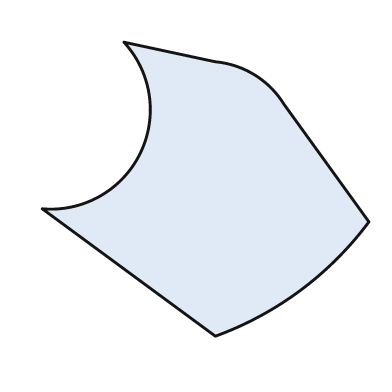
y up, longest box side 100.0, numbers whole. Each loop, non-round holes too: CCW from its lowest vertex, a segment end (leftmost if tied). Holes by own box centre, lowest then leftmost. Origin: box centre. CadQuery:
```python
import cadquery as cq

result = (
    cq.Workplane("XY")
    .moveTo(3.0, -45.0)
    .threePointArc((29.0, -31.0), (50.0, -10.0))
    .lineTo(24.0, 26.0)
    .threePointArc((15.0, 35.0), (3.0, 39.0))
    .lineTo(-25.0, 45.0)
    .threePointArc((-20.0, 11.0), (-50.0, -6.0))
    .close()
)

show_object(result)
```